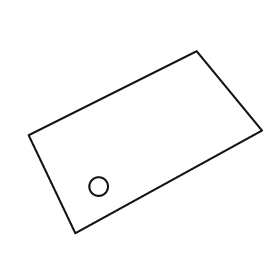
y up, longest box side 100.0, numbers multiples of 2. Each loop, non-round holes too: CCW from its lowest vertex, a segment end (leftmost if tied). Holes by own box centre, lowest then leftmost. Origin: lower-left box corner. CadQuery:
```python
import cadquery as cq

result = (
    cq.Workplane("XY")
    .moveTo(20.0, 0.0)
    .lineTo(100.0, 44.0)
    .lineTo(72.0, 78.0)
    .lineTo(0.0, 42.0)
    .close()
    .moveTo(30.0, 20.0)
    .circle(4.0)
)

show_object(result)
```